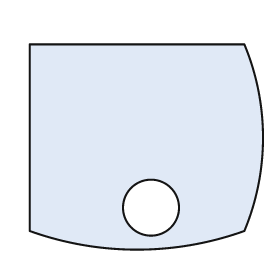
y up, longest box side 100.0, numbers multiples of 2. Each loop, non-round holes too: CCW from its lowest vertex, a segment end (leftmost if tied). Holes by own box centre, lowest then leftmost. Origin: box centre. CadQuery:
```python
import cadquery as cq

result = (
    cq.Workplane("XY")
    .moveTo(-50.0, -36.0)
    .threePointArc((-4.0, -44.0), (42.0, -36.0))
    .threePointArc((50.0, 4.0), (42.0, 44.0))
    .lineTo(-50.0, 44.0)
    .close()
    .moveTo(2.0, -26.0)
    .circle(12.0)
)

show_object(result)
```